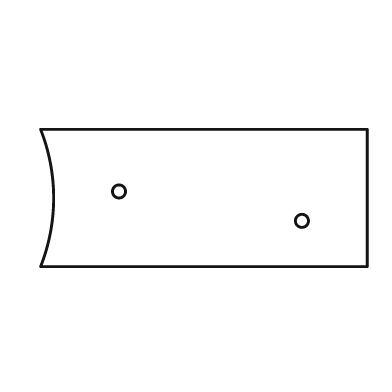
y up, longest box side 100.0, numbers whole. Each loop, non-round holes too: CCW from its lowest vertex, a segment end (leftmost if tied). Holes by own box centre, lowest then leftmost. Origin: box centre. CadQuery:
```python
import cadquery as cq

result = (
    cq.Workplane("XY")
    .moveTo(-50.0, -21.0)
    .lineTo(50.0, -21.0)
    .lineTo(50.0, 21.0)
    .lineTo(-50.0, 21.0)
    .threePointArc((-46.0, 0.0), (-50.0, -21.0))
    .close()
    .moveTo(30.0, -7.0)
    .circle(2.0)
    .moveTo(-26.0, 2.0)
    .circle(2.0)
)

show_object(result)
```